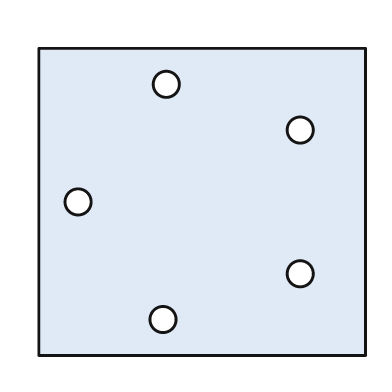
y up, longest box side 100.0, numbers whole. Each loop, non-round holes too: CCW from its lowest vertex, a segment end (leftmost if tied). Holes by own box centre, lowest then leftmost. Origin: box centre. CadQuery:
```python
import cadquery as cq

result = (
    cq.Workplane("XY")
    .moveTo(-50.0, -47.0)
    .lineTo(50.0, -47.0)
    .lineTo(50.0, 47.0)
    .lineTo(-50.0, 47.0)
    .close()
    .moveTo(-12.0, -36.0)
    .circle(4.0)
    .moveTo(30.0, -22.0)
    .circle(4.0)
    .moveTo(-38.0, 0.0)
    .circle(4.0)
    .moveTo(30.0, 22.0)
    .circle(4.0)
    .moveTo(-11.0, 36.0)
    .circle(4.0)
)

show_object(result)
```